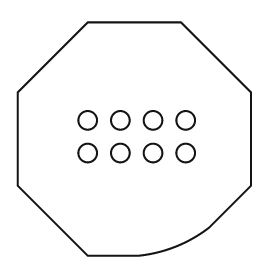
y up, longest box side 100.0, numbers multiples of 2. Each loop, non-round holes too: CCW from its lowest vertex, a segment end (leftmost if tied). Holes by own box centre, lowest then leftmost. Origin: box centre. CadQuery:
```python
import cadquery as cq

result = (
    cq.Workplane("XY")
    .moveTo(-20.0, -50.0)
    .lineTo(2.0, -50.0)
    .threePointArc((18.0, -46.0), (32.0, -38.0))
    .lineTo(50.0, -20.0)
    .lineTo(50.0, 20.0)
    .lineTo(20.0, 50.0)
    .lineTo(-20.0, 50.0)
    .lineTo(-50.0, 20.0)
    .lineTo(-50.0, -20.0)
    .close()
    .moveTo(-20.0, -6.0)
    .circle(4.0)
    .moveTo(-6.0, -6.0)
    .circle(4.0)
    .moveTo(8.0, -6.0)
    .circle(4.0)
    .moveTo(22.0, -6.0)
    .circle(4.0)
    .moveTo(-20.0, 8.0)
    .circle(4.0)
    .moveTo(-6.0, 8.0)
    .circle(4.0)
    .moveTo(8.0, 8.0)
    .circle(4.0)
    .moveTo(22.0, 8.0)
    .circle(4.0)
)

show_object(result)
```